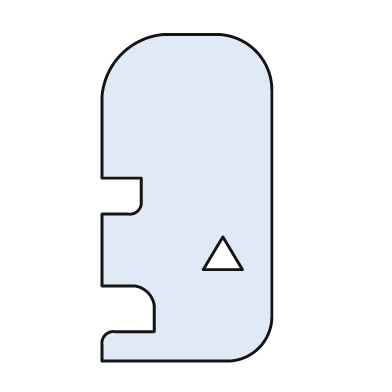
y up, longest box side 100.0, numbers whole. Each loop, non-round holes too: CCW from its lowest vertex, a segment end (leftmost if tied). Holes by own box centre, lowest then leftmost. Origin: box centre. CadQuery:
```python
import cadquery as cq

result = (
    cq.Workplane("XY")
    .moveTo(-26.0, -50.0)
    .lineTo(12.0, -50.0)
    .threePointArc((22.0, -46.0), (26.0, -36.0))
    .lineTo(26.0, 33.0)
    .threePointArc((21.0, 45.0), (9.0, 50.0))
    .lineTo(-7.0, 50.0)
    .threePointArc((-20.0, 44.0), (-26.0, 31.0))
    .lineTo(-26.0, 6.0)
    .lineTo(-14.0, 6.0)
    .lineTo(-14.0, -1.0)
    .threePointArc((-15.0, -4.0), (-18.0, -5.0))
    .lineTo(-26.0, -5.0)
    .lineTo(-26.0, -27.0)
    .lineTo(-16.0, -27.0)
    .threePointArc((-12.0, -29.0), (-10.0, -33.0))
    .lineTo(-10.0, -41.0)
    .lineTo(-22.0, -41.0)
    .threePointArc((-25.0, -42.0), (-26.0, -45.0))
    .close()
    .moveTo(5.0, -22.0)
    .lineTo(17.0, -22.0)
    .lineTo(11.0, -12.0)
    .close()
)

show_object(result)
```